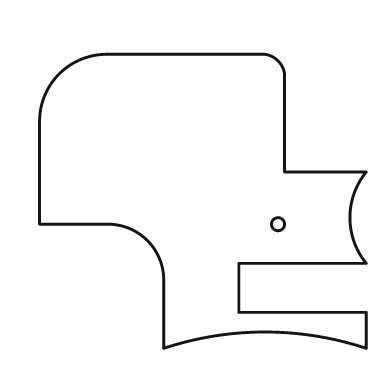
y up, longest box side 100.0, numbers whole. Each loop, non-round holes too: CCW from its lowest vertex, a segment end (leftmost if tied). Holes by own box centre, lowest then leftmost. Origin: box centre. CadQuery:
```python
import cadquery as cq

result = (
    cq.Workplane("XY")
    .moveTo(-12.0, -45.0)
    .threePointArc((19.0, -40.0), (50.0, -45.0))
    .lineTo(50.0, -34.0)
    .lineTo(11.0, -34.0)
    .lineTo(11.0, -19.0)
    .lineTo(50.0, -19.0)
    .threePointArc((45.0, -5.0), (50.0, 9.0))
    .lineTo(25.0, 9.0)
    .lineTo(25.0, 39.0)
    .threePointArc((23.0, 43.0), (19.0, 45.0))
    .lineTo(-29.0, 45.0)
    .threePointArc((-44.0, 39.0), (-50.0, 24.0))
    .lineTo(-50.0, -7.0)
    .lineTo(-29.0, -7.0)
    .threePointArc((-17.0, -12.0), (-12.0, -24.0))
    .close()
    .moveTo(23.0, -7.0)
    .circle(2.0)
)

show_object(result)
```